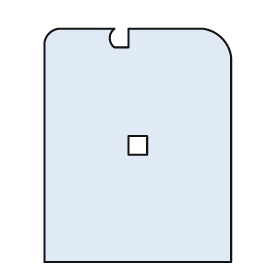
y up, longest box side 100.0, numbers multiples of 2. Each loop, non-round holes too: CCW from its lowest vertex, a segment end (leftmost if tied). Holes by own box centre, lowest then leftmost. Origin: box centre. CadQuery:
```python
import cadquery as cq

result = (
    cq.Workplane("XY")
    .moveTo(-40.0, -50.0)
    .lineTo(40.0, -50.0)
    .lineTo(40.0, 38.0)
    .threePointArc((36.0, 46.0), (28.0, 50.0))
    .lineTo(-4.0, 50.0)
    .lineTo(-4.0, 42.0)
    .lineTo(-10.0, 42.0)
    .threePointArc((-12.0, 46.0), (-10.0, 50.0))
    .lineTo(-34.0, 50.0)
    .threePointArc((-38.0, 48.0), (-40.0, 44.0))
    .close()
    .moveTo(-4.0, -4.0)
    .lineTo(4.0, -4.0)
    .lineTo(4.0, 4.0)
    .lineTo(-4.0, 4.0)
    .close()
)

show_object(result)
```